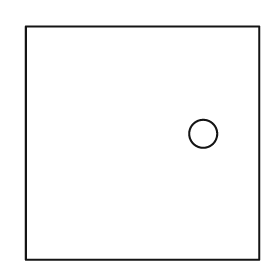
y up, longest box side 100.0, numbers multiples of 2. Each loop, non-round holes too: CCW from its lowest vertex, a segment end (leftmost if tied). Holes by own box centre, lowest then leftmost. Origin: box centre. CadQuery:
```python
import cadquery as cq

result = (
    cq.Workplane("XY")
    .moveTo(-50.0, -50.0)
    .lineTo(50.0, -50.0)
    .lineTo(50.0, 50.0)
    .lineTo(-50.0, 50.0)
    .close()
    .moveTo(26.0, 4.0)
    .circle(6.0)
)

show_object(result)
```